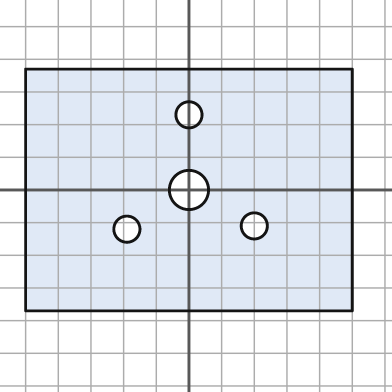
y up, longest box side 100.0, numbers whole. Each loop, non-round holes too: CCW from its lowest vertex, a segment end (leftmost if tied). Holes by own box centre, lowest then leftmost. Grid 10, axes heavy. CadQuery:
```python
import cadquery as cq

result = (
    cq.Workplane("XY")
    .moveTo(-50.0, -37.0)
    .lineTo(50.0, -37.0)
    .lineTo(50.0, 37.0)
    .lineTo(-50.0, 37.0)
    .close()
    .moveTo(-19.0, -12.0)
    .circle(4.0)
    .moveTo(20.0, -11.0)
    .circle(4.0)
    .moveTo(0.0, 0.0)
    .circle(6.0)
    .moveTo(0.0, 23.0)
    .circle(4.0)
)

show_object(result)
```